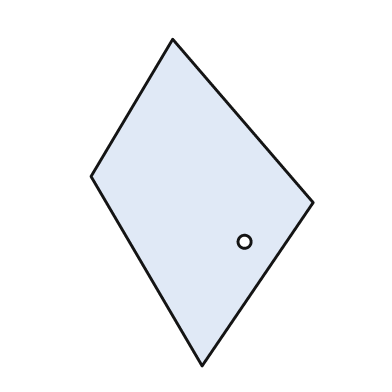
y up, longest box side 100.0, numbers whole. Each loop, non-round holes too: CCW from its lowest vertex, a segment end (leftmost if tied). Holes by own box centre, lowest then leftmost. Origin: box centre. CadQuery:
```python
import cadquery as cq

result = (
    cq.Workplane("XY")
    .moveTo(0.0, -50.0)
    .lineTo(34.0, 0.0)
    .lineTo(-9.0, 50.0)
    .lineTo(-34.0, 8.0)
    .close()
    .moveTo(13.0, -12.0)
    .circle(2.0)
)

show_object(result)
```